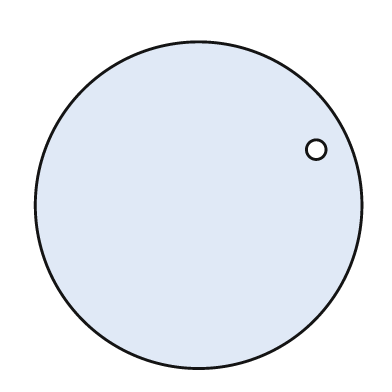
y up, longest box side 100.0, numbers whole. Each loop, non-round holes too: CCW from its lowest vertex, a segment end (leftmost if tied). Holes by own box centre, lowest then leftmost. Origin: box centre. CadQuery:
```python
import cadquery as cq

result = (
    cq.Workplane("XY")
    .moveTo(0.0, 0.0)
    .circle(50.0)
    .moveTo(36.0, 17.0)
    .circle(3.0)
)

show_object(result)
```